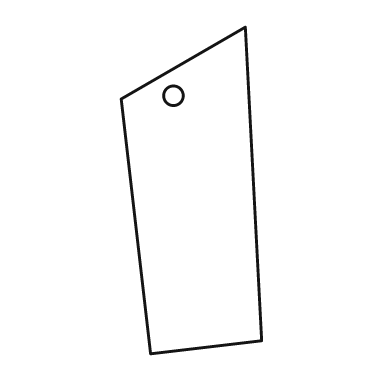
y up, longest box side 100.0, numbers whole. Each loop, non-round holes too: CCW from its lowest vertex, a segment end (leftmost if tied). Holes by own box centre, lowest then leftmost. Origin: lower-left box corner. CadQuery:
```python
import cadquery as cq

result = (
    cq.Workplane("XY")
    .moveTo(9.0, 0.0)
    .lineTo(43.0, 4.0)
    .lineTo(38.0, 100.0)
    .lineTo(0.0, 78.0)
    .close()
    .moveTo(16.0, 79.0)
    .circle(3.0)
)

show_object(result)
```